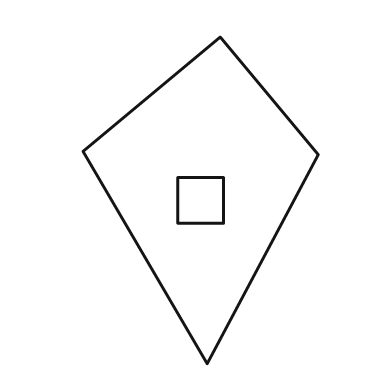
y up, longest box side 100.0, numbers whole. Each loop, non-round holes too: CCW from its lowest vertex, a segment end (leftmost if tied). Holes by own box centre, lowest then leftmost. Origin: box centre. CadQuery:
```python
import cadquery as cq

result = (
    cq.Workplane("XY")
    .moveTo(2.0, -50.0)
    .lineTo(36.0, 14.0)
    .lineTo(6.0, 50.0)
    .lineTo(-36.0, 15.0)
    .close()
    .moveTo(-7.0, -7.0)
    .lineTo(7.0, -7.0)
    .lineTo(7.0, 7.0)
    .lineTo(-7.0, 7.0)
    .close()
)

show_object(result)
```